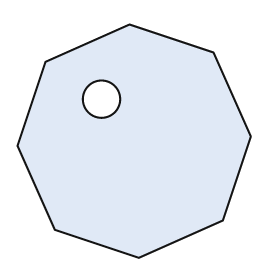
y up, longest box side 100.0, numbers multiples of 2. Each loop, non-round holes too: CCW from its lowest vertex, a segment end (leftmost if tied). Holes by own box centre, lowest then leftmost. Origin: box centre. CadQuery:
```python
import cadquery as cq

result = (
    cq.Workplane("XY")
    .moveTo(2.0, -50.0)
    .lineTo(38.0, -34.0)
    .lineTo(50.0, 2.0)
    .lineTo(34.0, 38.0)
    .lineTo(-2.0, 50.0)
    .lineTo(-38.0, 34.0)
    .lineTo(-50.0, -2.0)
    .lineTo(-34.0, -38.0)
    .close()
    .moveTo(-14.0, 18.0)
    .circle(8.0)
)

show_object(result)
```